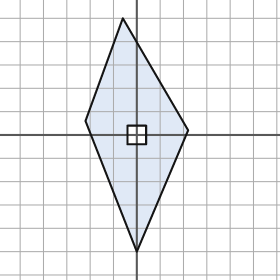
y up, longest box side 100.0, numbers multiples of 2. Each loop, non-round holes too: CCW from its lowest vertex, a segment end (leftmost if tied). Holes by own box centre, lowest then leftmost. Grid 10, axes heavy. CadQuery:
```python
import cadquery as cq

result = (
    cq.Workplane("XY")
    .moveTo(0.0, -50.0)
    .lineTo(22.0, 2.0)
    .lineTo(-6.0, 50.0)
    .lineTo(-22.0, 6.0)
    .close()
    .moveTo(-4.0, -4.0)
    .lineTo(4.0, -4.0)
    .lineTo(4.0, 4.0)
    .lineTo(-4.0, 4.0)
    .close()
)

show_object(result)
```